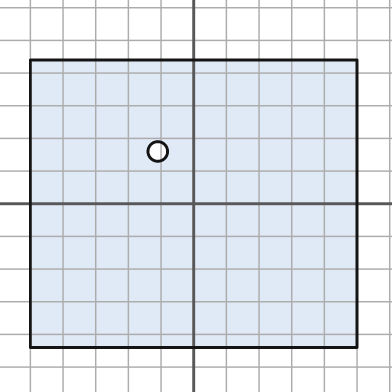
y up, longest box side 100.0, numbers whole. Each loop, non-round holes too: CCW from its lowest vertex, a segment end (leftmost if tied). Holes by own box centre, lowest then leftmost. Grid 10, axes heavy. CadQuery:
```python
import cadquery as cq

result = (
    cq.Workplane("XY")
    .moveTo(-50.0, -44.0)
    .lineTo(50.0, -44.0)
    .lineTo(50.0, 44.0)
    .lineTo(-50.0, 44.0)
    .close()
    .moveTo(-11.0, 16.0)
    .circle(3.0)
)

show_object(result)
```